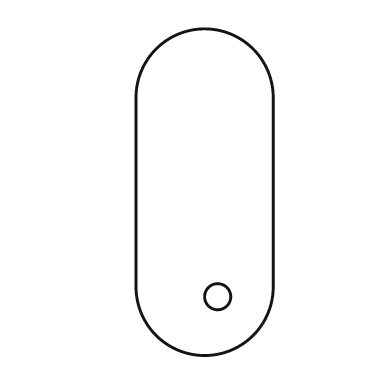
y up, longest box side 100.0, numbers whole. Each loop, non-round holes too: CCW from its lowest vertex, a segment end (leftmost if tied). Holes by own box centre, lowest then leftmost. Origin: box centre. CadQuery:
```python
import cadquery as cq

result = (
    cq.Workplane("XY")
    .moveTo(-21.0, -29.0)
    .threePointArc((0.0, -50.0), (21.0, -29.0))
    .lineTo(21.0, 29.0)
    .threePointArc((0.0, 50.0), (-21.0, 29.0))
    .close()
    .moveTo(4.0, -32.0)
    .circle(4.0)
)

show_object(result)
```